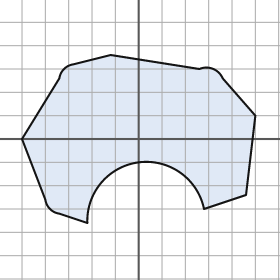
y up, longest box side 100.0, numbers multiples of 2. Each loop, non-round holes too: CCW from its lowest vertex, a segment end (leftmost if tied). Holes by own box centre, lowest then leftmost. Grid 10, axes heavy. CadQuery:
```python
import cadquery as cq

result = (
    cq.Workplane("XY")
    .moveTo(-22.0, -36.0)
    .threePointArc((0.0, -10.0), (28.0, -30.0))
    .lineTo(46.0, -24.0)
    .lineTo(50.0, 10.0)
    .lineTo(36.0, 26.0)
    .threePointArc((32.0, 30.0), (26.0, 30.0))
    .lineTo(-12.0, 36.0)
    .lineTo(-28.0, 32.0)
    .threePointArc((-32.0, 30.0), (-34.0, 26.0))
    .lineTo(-50.0, 0.0)
    .lineTo(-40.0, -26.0)
    .threePointArc((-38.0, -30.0), (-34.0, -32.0))
    .close()
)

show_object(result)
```